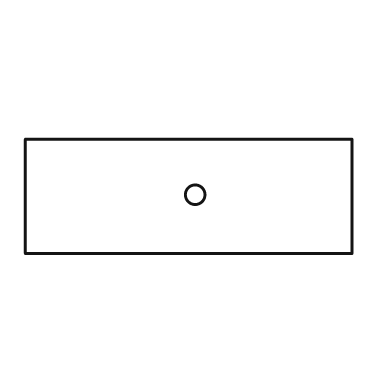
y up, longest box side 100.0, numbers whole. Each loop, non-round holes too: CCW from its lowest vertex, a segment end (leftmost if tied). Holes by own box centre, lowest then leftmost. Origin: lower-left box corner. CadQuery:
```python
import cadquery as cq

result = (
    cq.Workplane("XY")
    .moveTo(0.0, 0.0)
    .lineTo(100.0, 0.0)
    .lineTo(100.0, 35.0)
    .lineTo(0.0, 35.0)
    .close()
    .moveTo(52.0, 18.0)
    .circle(3.0)
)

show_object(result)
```